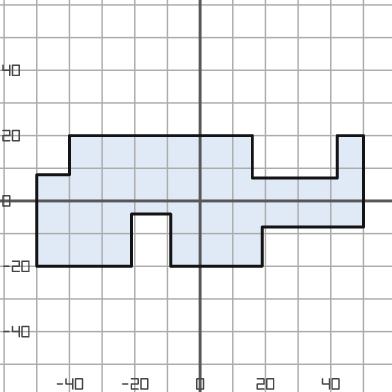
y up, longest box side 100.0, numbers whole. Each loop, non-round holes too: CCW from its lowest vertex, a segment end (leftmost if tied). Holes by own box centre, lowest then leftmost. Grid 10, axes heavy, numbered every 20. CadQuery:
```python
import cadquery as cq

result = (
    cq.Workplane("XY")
    .moveTo(-50.0, -20.0)
    .lineTo(-21.0, -20.0)
    .lineTo(-21.0, -4.0)
    .lineTo(-9.0, -4.0)
    .lineTo(-9.0, -20.0)
    .lineTo(19.0, -20.0)
    .lineTo(19.0, -8.0)
    .lineTo(50.0, -8.0)
    .lineTo(50.0, 20.0)
    .lineTo(42.0, 20.0)
    .lineTo(42.0, 7.0)
    .lineTo(16.0, 7.0)
    .lineTo(16.0, 20.0)
    .lineTo(-40.0, 20.0)
    .lineTo(-40.0, 8.0)
    .lineTo(-50.0, 8.0)
    .close()
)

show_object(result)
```